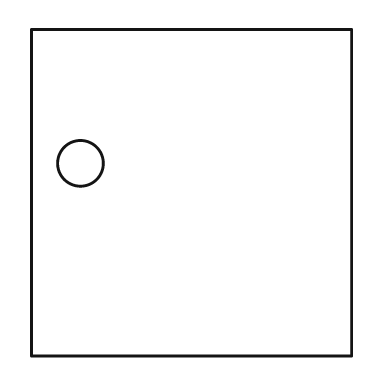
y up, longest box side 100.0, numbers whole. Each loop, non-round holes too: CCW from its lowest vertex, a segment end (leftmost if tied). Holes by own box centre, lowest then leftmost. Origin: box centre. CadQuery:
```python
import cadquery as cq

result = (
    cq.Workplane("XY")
    .moveTo(-49.0, -50.0)
    .lineTo(49.0, -50.0)
    .lineTo(49.0, 50.0)
    .lineTo(-49.0, 50.0)
    .close()
    .moveTo(-34.0, 9.0)
    .circle(7.0)
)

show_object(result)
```